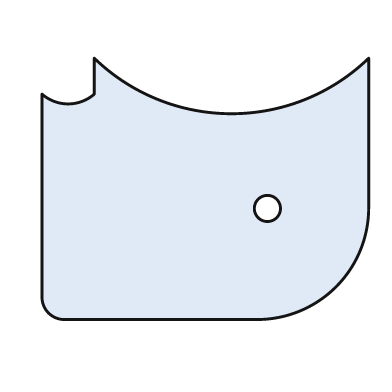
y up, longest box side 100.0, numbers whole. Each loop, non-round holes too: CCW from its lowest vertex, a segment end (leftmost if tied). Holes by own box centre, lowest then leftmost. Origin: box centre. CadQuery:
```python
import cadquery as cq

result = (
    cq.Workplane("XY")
    .moveTo(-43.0, -40.0)
    .lineTo(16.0, -40.0)
    .threePointArc((40.0, -30.0), (50.0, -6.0))
    .lineTo(50.0, 40.0)
    .threePointArc((8.0, 23.0), (-34.0, 40.0))
    .lineTo(-34.0, 29.0)
    .threePointArc((-42.0, 26.0), (-50.0, 29.0))
    .lineTo(-50.0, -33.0)
    .threePointArc((-48.0, -38.0), (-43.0, -40.0))
    .close()
    .moveTo(19.0, -6.0)
    .circle(4.0)
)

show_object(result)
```